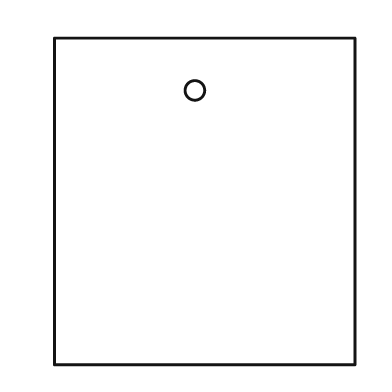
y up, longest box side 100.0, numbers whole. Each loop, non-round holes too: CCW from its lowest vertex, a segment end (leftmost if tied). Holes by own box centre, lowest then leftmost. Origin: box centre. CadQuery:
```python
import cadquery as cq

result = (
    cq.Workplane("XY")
    .moveTo(-46.0, -50.0)
    .lineTo(46.0, -50.0)
    .lineTo(46.0, 50.0)
    .lineTo(-46.0, 50.0)
    .close()
    .moveTo(-3.0, 34.0)
    .circle(3.0)
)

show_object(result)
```